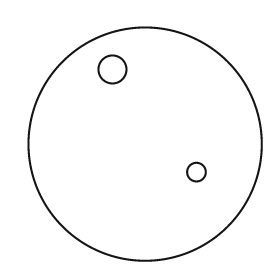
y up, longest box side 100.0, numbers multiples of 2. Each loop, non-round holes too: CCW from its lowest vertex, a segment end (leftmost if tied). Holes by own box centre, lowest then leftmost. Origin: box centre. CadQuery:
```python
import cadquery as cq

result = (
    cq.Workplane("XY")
    .moveTo(0.0, 0.0)
    .circle(50.0)
    .moveTo(22.0, -12.0)
    .circle(4.0)
    .moveTo(-14.0, 32.0)
    .circle(6.0)
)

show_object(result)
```